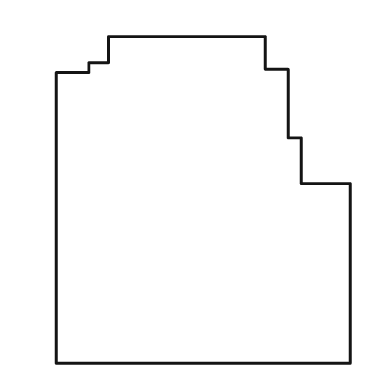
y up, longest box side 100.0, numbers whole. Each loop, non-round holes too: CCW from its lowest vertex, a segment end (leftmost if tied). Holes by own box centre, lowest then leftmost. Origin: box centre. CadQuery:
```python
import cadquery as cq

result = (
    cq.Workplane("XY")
    .moveTo(-45.0, -50.0)
    .lineTo(45.0, -50.0)
    .lineTo(45.0, 5.0)
    .lineTo(30.0, 5.0)
    .lineTo(30.0, 19.0)
    .lineTo(26.0, 19.0)
    .lineTo(26.0, 40.0)
    .lineTo(19.0, 40.0)
    .lineTo(19.0, 50.0)
    .lineTo(-29.0, 50.0)
    .lineTo(-29.0, 42.0)
    .lineTo(-35.0, 42.0)
    .lineTo(-35.0, 39.0)
    .lineTo(-45.0, 39.0)
    .close()
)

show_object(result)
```